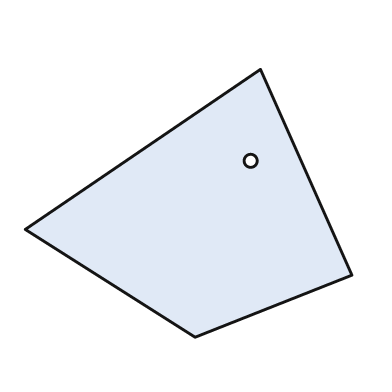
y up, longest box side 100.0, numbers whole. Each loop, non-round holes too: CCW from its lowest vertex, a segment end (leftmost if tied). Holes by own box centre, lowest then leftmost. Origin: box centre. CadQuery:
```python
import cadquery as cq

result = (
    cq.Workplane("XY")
    .moveTo(2.0, -41.0)
    .lineTo(50.0, -22.0)
    .lineTo(22.0, 41.0)
    .lineTo(-50.0, -8.0)
    .close()
    .moveTo(19.0, 13.0)
    .circle(2.0)
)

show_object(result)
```